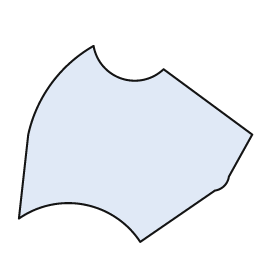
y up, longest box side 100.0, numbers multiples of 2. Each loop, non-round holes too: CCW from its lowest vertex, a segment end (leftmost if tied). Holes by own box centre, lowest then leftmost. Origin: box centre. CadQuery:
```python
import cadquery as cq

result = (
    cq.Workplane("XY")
    .moveTo(2.0, -42.0)
    .lineTo(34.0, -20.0)
    .threePointArc((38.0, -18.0), (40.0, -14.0))
    .lineTo(50.0, 4.0)
    .lineTo(12.0, 32.0)
    .threePointArc((-6.0, 28.0), (-18.0, 42.0))
    .threePointArc((-36.0, 26.0), (-46.0, 4.0))
    .lineTo(-50.0, -32.0)
    .threePointArc((-22.0, -26.0), (2.0, -42.0))
    .close()
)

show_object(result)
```